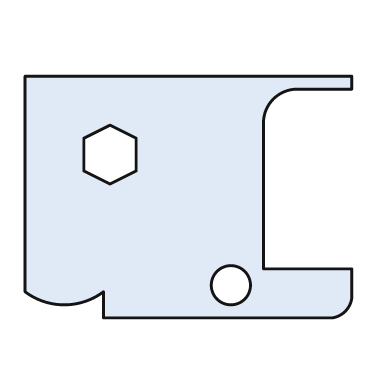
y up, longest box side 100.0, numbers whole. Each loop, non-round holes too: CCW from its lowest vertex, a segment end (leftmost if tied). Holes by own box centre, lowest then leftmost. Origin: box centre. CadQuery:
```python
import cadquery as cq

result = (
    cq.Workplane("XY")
    .moveTo(-26.0, -37.0)
    .lineTo(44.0, -37.0)
    .threePointArc((48.0, -35.0), (50.0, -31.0))
    .lineTo(50.0, -22.0)
    .lineTo(23.0, -22.0)
    .lineTo(23.0, 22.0)
    .threePointArc((26.0, 30.0), (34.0, 33.0))
    .lineTo(50.0, 33.0)
    .lineTo(50.0, 37.0)
    .lineTo(-50.0, 37.0)
    .lineTo(-50.0, -29.0)
    .threePointArc((-38.0, -33.0), (-26.0, -29.0))
    .close()
    .moveTo(13.0, -27.0)
    .circle(6.0)
    .moveTo(-24.0, 4.0)
    .lineTo(-16.0, 8.0)
    .lineTo(-16.0, 18.0)
    .lineTo(-24.0, 22.0)
    .lineTo(-32.0, 18.0)
    .lineTo(-32.0, 8.0)
    .close()
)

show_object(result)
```